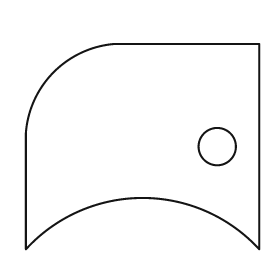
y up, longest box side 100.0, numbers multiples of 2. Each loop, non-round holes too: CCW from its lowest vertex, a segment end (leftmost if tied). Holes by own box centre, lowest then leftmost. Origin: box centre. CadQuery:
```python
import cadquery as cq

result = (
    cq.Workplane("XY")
    .moveTo(-50.0, -44.0)
    .threePointArc((0.0, -22.0), (50.0, -44.0))
    .lineTo(50.0, 44.0)
    .lineTo(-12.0, 44.0)
    .threePointArc((-38.0, 32.0), (-50.0, 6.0))
    .close()
    .moveTo(32.0, 0.0)
    .circle(8.0)
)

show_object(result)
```